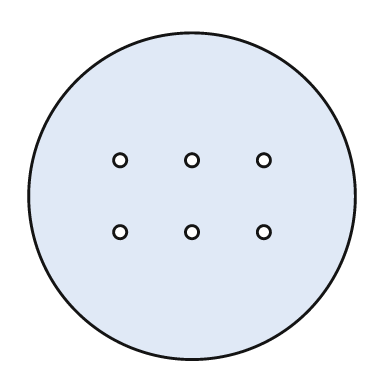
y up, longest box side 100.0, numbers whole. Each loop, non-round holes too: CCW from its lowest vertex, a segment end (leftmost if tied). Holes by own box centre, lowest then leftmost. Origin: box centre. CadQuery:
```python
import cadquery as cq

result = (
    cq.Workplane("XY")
    .moveTo(0.0, 0.0)
    .circle(50.0)
    .moveTo(-22.0, -11.0)
    .circle(2.0)
    .moveTo(0.0, -11.0)
    .circle(2.0)
    .moveTo(22.0, -11.0)
    .circle(2.0)
    .moveTo(-22.0, 11.0)
    .circle(2.0)
    .moveTo(0.0, 11.0)
    .circle(2.0)
    .moveTo(22.0, 11.0)
    .circle(2.0)
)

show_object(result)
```